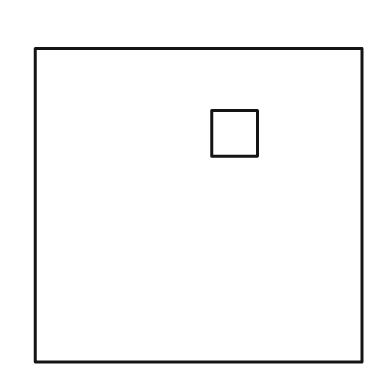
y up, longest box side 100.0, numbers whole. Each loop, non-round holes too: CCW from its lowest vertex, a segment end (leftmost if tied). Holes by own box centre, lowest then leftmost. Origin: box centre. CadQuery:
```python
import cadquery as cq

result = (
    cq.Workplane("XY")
    .moveTo(-50.0, -48.0)
    .lineTo(50.0, -48.0)
    .lineTo(50.0, 48.0)
    .lineTo(-50.0, 48.0)
    .close()
    .moveTo(4.0, 15.0)
    .lineTo(18.0, 15.0)
    .lineTo(18.0, 29.0)
    .lineTo(4.0, 29.0)
    .close()
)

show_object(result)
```